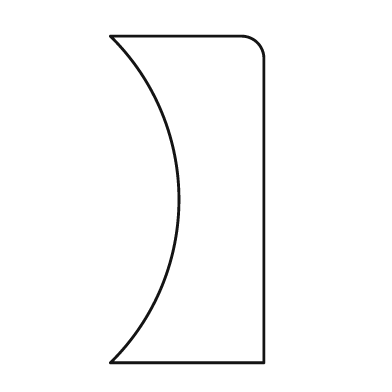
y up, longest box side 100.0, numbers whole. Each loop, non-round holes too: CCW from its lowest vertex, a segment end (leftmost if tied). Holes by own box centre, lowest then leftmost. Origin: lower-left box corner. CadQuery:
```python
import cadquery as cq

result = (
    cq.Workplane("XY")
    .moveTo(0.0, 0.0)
    .lineTo(47.0, 0.0)
    .lineTo(47.0, 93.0)
    .threePointArc((45.0, 98.0), (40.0, 100.0))
    .lineTo(0.0, 100.0)
    .threePointArc((21.0, 50.0), (0.0, 0.0))
    .close()
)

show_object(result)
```